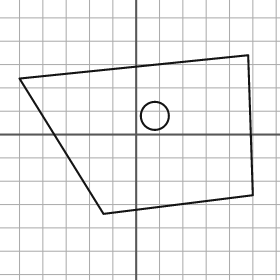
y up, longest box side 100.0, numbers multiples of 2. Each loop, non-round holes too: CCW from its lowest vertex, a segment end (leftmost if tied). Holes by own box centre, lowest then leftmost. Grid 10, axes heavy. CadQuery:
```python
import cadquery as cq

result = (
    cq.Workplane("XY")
    .moveTo(-14.0, -34.0)
    .lineTo(50.0, -26.0)
    .lineTo(48.0, 34.0)
    .lineTo(-50.0, 24.0)
    .close()
    .moveTo(8.0, 8.0)
    .circle(6.0)
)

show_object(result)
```